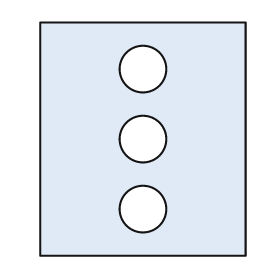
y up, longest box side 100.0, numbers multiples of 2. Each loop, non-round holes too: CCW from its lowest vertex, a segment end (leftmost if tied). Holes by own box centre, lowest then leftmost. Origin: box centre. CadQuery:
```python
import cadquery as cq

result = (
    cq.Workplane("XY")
    .moveTo(-44.0, -50.0)
    .lineTo(44.0, -50.0)
    .lineTo(44.0, 50.0)
    .lineTo(-44.0, 50.0)
    .close()
    .moveTo(0.0, -30.0)
    .circle(10.0)
    .moveTo(0.0, 0.0)
    .circle(10.0)
    .moveTo(0.0, 30.0)
    .circle(10.0)
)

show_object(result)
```